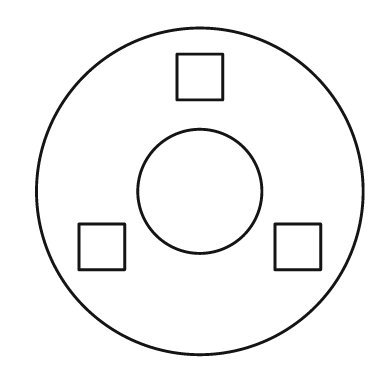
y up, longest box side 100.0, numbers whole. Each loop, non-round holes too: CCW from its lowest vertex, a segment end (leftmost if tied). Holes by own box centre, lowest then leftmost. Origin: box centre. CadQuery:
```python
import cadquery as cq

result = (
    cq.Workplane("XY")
    .moveTo(0.0, 0.0)
    .circle(50.0)
    .moveTo(-37.0, -24.0)
    .lineTo(-23.0, -24.0)
    .lineTo(-23.0, -10.0)
    .lineTo(-37.0, -10.0)
    .close()
    .moveTo(23.0, -24.0)
    .lineTo(37.0, -24.0)
    .lineTo(37.0, -10.0)
    .lineTo(23.0, -10.0)
    .close()
    .moveTo(0.0, 0.0)
    .circle(19.0)
    .moveTo(-7.0, 28.0)
    .lineTo(7.0, 28.0)
    .lineTo(7.0, 42.0)
    .lineTo(-7.0, 42.0)
    .close()
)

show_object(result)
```